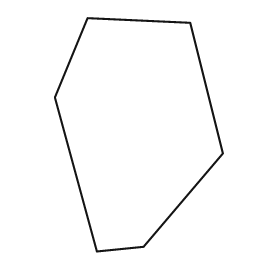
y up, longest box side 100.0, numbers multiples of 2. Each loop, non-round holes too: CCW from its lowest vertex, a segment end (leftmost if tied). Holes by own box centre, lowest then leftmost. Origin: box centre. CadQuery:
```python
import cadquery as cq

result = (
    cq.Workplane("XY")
    .moveTo(-18.0, -50.0)
    .lineTo(2.0, -48.0)
    .lineTo(36.0, -8.0)
    .lineTo(22.0, 48.0)
    .lineTo(-22.0, 50.0)
    .lineTo(-36.0, 16.0)
    .close()
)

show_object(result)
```